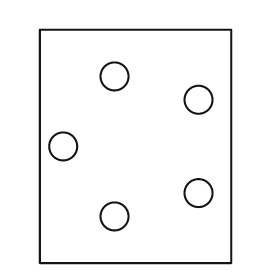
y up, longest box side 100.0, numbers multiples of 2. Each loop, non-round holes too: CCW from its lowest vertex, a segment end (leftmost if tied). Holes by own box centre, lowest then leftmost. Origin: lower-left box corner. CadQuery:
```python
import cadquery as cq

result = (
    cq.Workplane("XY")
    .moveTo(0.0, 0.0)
    .lineTo(82.0, 0.0)
    .lineTo(82.0, 100.0)
    .lineTo(0.0, 100.0)
    .close()
    .moveTo(32.0, 20.0)
    .circle(6.0)
    .moveTo(68.0, 30.0)
    .circle(6.0)
    .moveTo(10.0, 50.0)
    .circle(6.0)
    .moveTo(68.0, 70.0)
    .circle(6.0)
    .moveTo(32.0, 80.0)
    .circle(6.0)
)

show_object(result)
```